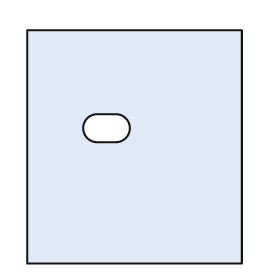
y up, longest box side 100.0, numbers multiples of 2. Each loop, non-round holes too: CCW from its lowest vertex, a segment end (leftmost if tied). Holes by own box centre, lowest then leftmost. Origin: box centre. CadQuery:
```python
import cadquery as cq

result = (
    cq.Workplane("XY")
    .moveTo(-46.0, -50.0)
    .lineTo(46.0, -50.0)
    .lineTo(46.0, 50.0)
    .lineTo(-46.0, 50.0)
    .close()
    .moveTo(-16.0, 2.0)
    .lineTo(-8.0, 2.0)
    .threePointArc((-2.0, 8.0), (-8.0, 14.0))
    .lineTo(-16.0, 14.0)
    .threePointArc((-22.0, 8.0), (-16.0, 2.0))
    .close()
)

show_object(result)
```